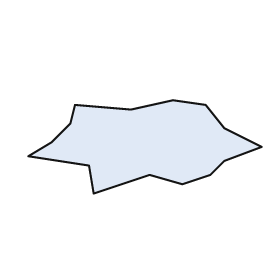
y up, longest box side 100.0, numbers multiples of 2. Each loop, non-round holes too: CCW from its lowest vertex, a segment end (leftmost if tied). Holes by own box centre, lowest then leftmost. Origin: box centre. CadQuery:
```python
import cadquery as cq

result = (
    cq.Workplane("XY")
    .moveTo(-22.0, -20.0)
    .lineTo(2.0, -12.0)
    .lineTo(16.0, -16.0)
    .lineTo(28.0, -12.0)
    .lineTo(34.0, -6.0)
    .lineTo(50.0, 0.0)
    .lineTo(34.0, 8.0)
    .lineTo(26.0, 18.0)
    .lineTo(12.0, 20.0)
    .lineTo(-6.0, 16.0)
    .lineTo(-30.0, 18.0)
    .lineTo(-32.0, 10.0)
    .lineTo(-40.0, 2.0)
    .lineTo(-50.0, -4.0)
    .lineTo(-24.0, -8.0)
    .close()
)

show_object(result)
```